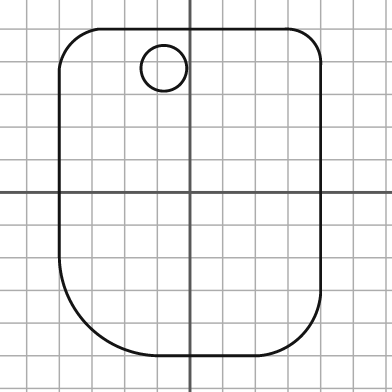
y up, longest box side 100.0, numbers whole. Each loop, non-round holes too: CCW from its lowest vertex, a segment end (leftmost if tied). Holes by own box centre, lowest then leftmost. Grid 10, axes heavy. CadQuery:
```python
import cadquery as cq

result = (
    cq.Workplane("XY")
    .moveTo(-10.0, -50.0)
    .lineTo(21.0, -50.0)
    .threePointArc((34.0, -44.0), (40.0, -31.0))
    .lineTo(40.0, 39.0)
    .threePointArc((37.0, 47.0), (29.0, 50.0))
    .lineTo(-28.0, 50.0)
    .threePointArc((-36.0, 46.0), (-40.0, 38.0))
    .lineTo(-40.0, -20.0)
    .threePointArc((-31.0, -41.0), (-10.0, -50.0))
    .close()
    .moveTo(-8.0, 38.0)
    .circle(7.0)
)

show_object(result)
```